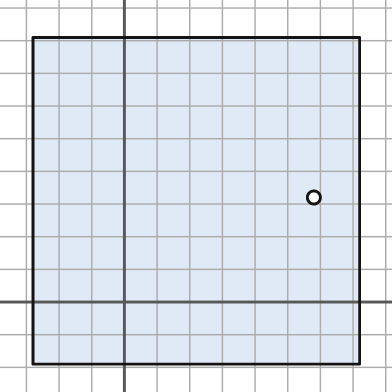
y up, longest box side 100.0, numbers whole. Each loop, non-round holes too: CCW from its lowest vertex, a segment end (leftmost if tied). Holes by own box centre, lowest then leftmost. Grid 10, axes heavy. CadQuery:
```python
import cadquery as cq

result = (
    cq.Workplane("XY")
    .moveTo(-28.0, -19.0)
    .lineTo(72.0, -19.0)
    .lineTo(72.0, 81.0)
    .lineTo(-28.0, 81.0)
    .close()
    .moveTo(58.0, 32.0)
    .circle(2.0)
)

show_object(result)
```